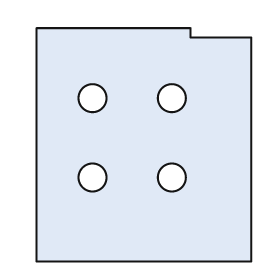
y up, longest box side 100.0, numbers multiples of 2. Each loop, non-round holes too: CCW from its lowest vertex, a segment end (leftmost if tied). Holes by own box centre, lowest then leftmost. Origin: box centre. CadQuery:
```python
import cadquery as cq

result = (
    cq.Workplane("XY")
    .moveTo(-46.0, -50.0)
    .lineTo(46.0, -50.0)
    .lineTo(46.0, 46.0)
    .lineTo(20.0, 46.0)
    .lineTo(20.0, 50.0)
    .lineTo(-46.0, 50.0)
    .close()
    .moveTo(-22.0, -14.0)
    .circle(6.0)
    .moveTo(12.0, -14.0)
    .circle(6.0)
    .moveTo(-22.0, 20.0)
    .circle(6.0)
    .moveTo(12.0, 20.0)
    .circle(6.0)
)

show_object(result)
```